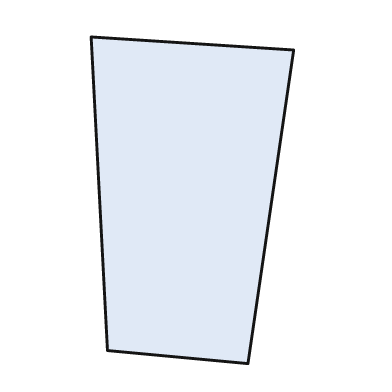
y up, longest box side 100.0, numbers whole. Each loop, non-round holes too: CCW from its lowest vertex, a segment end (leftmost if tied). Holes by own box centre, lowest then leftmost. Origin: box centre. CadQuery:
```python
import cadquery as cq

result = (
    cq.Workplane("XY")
    .moveTo(17.0, -50.0)
    .lineTo(31.0, 46.0)
    .lineTo(-31.0, 50.0)
    .lineTo(-26.0, -46.0)
    .close()
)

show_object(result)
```